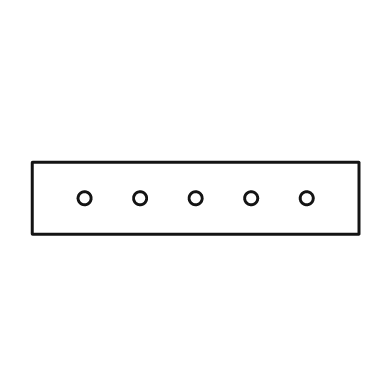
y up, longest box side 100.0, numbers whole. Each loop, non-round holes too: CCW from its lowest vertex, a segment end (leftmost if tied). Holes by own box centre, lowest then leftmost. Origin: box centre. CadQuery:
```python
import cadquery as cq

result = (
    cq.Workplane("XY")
    .moveTo(-50.0, -11.0)
    .lineTo(50.0, -11.0)
    .lineTo(50.0, 11.0)
    .lineTo(-50.0, 11.0)
    .close()
    .moveTo(-34.0, 0.0)
    .circle(2.0)
    .moveTo(-17.0, 0.0)
    .circle(2.0)
    .moveTo(0.0, 0.0)
    .circle(2.0)
    .moveTo(17.0, 0.0)
    .circle(2.0)
    .moveTo(34.0, 0.0)
    .circle(2.0)
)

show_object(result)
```